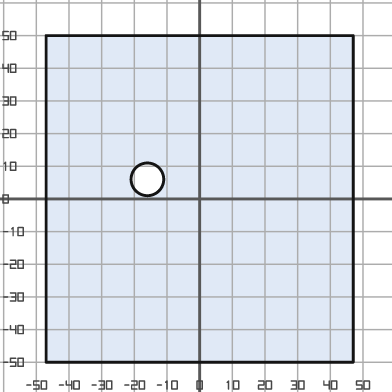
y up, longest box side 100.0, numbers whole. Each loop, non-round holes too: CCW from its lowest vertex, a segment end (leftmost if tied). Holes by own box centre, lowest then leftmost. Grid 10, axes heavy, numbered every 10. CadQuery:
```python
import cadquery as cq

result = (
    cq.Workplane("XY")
    .moveTo(-47.0, -50.0)
    .lineTo(47.0, -50.0)
    .lineTo(47.0, 50.0)
    .lineTo(-47.0, 50.0)
    .close()
    .moveTo(-16.0, 6.0)
    .circle(5.0)
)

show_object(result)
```